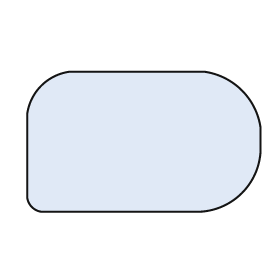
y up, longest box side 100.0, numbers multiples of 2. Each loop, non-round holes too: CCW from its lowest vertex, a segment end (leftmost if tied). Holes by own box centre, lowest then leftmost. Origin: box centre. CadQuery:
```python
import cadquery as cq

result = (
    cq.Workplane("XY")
    .moveTo(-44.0, -30.0)
    .lineTo(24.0, -30.0)
    .threePointArc((42.0, -22.0), (50.0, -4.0))
    .lineTo(50.0, 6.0)
    .threePointArc((42.0, 22.0), (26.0, 30.0))
    .lineTo(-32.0, 30.0)
    .threePointArc((-44.0, 24.0), (-50.0, 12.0))
    .lineTo(-50.0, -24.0)
    .threePointArc((-48.0, -28.0), (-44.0, -30.0))
    .close()
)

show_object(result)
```